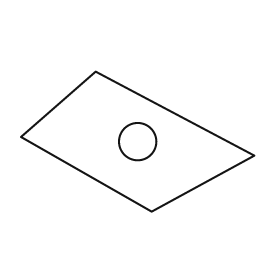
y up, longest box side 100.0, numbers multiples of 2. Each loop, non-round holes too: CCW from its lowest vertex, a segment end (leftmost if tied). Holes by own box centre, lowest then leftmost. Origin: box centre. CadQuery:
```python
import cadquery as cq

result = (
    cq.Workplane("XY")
    .moveTo(6.0, -30.0)
    .lineTo(50.0, -6.0)
    .lineTo(-18.0, 30.0)
    .lineTo(-50.0, 2.0)
    .close()
    .moveTo(0.0, 0.0)
    .circle(8.0)
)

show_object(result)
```